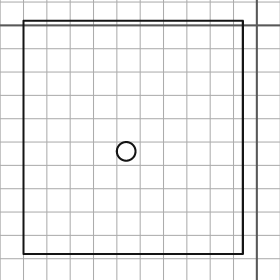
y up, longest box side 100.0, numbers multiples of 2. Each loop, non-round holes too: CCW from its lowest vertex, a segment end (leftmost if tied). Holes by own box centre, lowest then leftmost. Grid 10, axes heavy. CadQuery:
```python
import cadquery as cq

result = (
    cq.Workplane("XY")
    .moveTo(-100.0, -98.0)
    .lineTo(-6.0, -98.0)
    .lineTo(-6.0, 2.0)
    .lineTo(-100.0, 2.0)
    .close()
    .moveTo(-56.0, -54.0)
    .circle(4.0)
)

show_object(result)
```